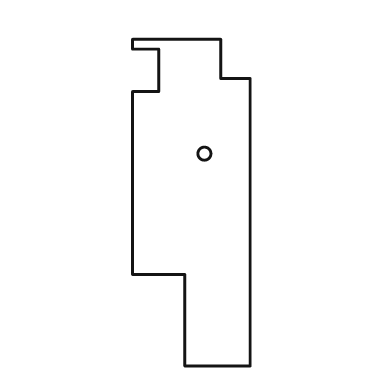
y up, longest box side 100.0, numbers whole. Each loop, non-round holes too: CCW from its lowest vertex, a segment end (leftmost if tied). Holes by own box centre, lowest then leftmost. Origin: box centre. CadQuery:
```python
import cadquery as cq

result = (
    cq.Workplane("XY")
    .moveTo(-2.0, -50.0)
    .lineTo(18.0, -50.0)
    .lineTo(18.0, 38.0)
    .lineTo(9.0, 38.0)
    .lineTo(9.0, 50.0)
    .lineTo(-18.0, 50.0)
    .lineTo(-18.0, 47.0)
    .lineTo(-10.0, 47.0)
    .lineTo(-10.0, 34.0)
    .lineTo(-18.0, 34.0)
    .lineTo(-18.0, -22.0)
    .lineTo(-2.0, -22.0)
    .close()
    .moveTo(4.0, 15.0)
    .circle(2.0)
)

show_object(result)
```